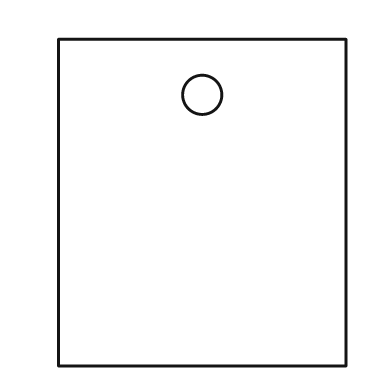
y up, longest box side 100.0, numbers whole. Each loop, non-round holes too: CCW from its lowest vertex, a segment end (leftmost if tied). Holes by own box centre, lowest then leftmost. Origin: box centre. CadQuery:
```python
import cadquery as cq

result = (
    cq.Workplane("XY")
    .moveTo(-44.0, -50.0)
    .lineTo(44.0, -50.0)
    .lineTo(44.0, 50.0)
    .lineTo(-44.0, 50.0)
    .close()
    .moveTo(0.0, 33.0)
    .circle(6.0)
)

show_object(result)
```